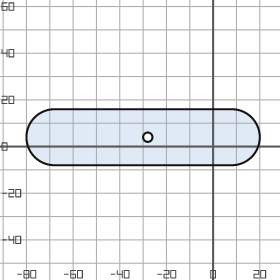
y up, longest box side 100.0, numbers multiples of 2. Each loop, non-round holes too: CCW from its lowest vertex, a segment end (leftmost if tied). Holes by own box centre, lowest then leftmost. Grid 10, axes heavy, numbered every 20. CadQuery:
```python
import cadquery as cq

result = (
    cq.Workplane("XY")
    .moveTo(-68.0, -8.0)
    .lineTo(8.0, -8.0)
    .threePointArc((20.0, 4.0), (8.0, 16.0))
    .lineTo(-68.0, 16.0)
    .threePointArc((-80.0, 4.0), (-68.0, -8.0))
    .close()
    .moveTo(-28.0, 4.0)
    .circle(2.0)
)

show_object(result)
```